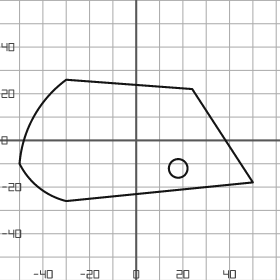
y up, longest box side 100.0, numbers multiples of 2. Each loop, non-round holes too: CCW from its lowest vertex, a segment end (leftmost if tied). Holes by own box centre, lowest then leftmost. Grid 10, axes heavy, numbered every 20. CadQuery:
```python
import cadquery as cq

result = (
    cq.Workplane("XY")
    .moveTo(-30.0, -26.0)
    .lineTo(50.0, -18.0)
    .lineTo(24.0, 22.0)
    .lineTo(-30.0, 26.0)
    .threePointArc((-44.0, 10.0), (-50.0, -10.0))
    .threePointArc((-42.0, -20.0), (-30.0, -26.0))
    .close()
    .moveTo(18.0, -12.0)
    .circle(4.0)
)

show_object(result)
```